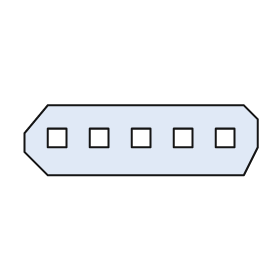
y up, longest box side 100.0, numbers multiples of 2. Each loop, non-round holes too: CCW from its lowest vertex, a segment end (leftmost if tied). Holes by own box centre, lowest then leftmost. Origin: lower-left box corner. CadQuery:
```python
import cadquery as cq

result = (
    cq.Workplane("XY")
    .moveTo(10.0, 0.0)
    .lineTo(94.0, 0.0)
    .lineTo(100.0, 12.0)
    .lineTo(100.0, 24.0)
    .lineTo(94.0, 30.0)
    .lineTo(10.0, 30.0)
    .lineTo(0.0, 18.0)
    .lineTo(0.0, 10.0)
    .close()
    .moveTo(10.0, 12.0)
    .lineTo(18.0, 12.0)
    .lineTo(18.0, 20.0)
    .lineTo(10.0, 20.0)
    .close()
    .moveTo(28.0, 12.0)
    .lineTo(36.0, 12.0)
    .lineTo(36.0, 20.0)
    .lineTo(28.0, 20.0)
    .close()
    .moveTo(46.0, 12.0)
    .lineTo(54.0, 12.0)
    .lineTo(54.0, 20.0)
    .lineTo(46.0, 20.0)
    .close()
    .moveTo(64.0, 12.0)
    .lineTo(72.0, 12.0)
    .lineTo(72.0, 20.0)
    .lineTo(64.0, 20.0)
    .close()
    .moveTo(82.0, 12.0)
    .lineTo(90.0, 12.0)
    .lineTo(90.0, 20.0)
    .lineTo(82.0, 20.0)
    .close()
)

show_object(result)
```